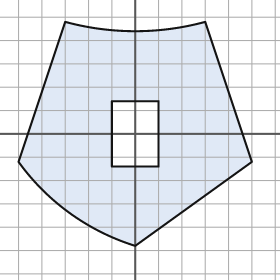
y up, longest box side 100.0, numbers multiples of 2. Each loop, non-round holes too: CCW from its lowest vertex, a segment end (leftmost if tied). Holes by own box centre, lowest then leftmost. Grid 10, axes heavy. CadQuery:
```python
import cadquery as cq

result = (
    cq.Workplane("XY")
    .moveTo(0.0, -48.0)
    .lineTo(50.0, -12.0)
    .lineTo(30.0, 48.0)
    .threePointArc((0.0, 44.0), (-30.0, 48.0))
    .lineTo(-50.0, -12.0)
    .threePointArc((-28.0, -34.0), (0.0, -48.0))
    .close()
    .moveTo(-10.0, -14.0)
    .lineTo(10.0, -14.0)
    .lineTo(10.0, 14.0)
    .lineTo(-10.0, 14.0)
    .close()
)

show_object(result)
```